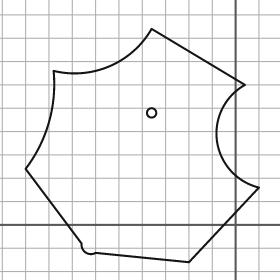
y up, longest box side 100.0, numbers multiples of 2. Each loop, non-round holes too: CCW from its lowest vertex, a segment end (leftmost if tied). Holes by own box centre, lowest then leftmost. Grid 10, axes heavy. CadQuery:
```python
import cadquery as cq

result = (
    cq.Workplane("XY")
    .moveTo(-20.0, -16.0)
    .lineTo(10.0, 16.0)
    .threePointArc((-8.0, 36.0), (4.0, 60.0))
    .lineTo(-36.0, 84.0)
    .threePointArc((-54.0, 68.0), (-78.0, 66.0))
    .threePointArc((-80.0, 44.0), (-90.0, 24.0))
    .lineTo(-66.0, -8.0)
    .threePointArc((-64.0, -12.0), (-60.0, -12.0))
    .close()
    .moveTo(-36.0, 48.0)
    .circle(2.0)
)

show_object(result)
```